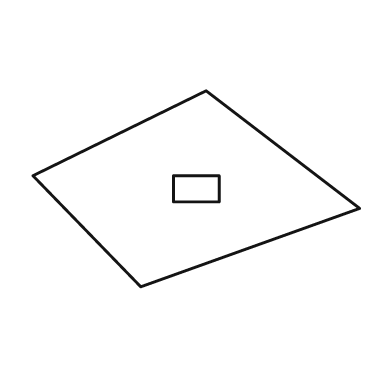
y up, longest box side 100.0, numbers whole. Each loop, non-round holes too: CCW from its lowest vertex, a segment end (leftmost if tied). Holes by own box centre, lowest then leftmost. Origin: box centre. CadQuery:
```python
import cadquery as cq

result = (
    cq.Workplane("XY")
    .moveTo(-17.0, -30.0)
    .lineTo(50.0, -6.0)
    .lineTo(3.0, 30.0)
    .lineTo(-50.0, 4.0)
    .close()
    .moveTo(-7.0, -4.0)
    .lineTo(7.0, -4.0)
    .lineTo(7.0, 4.0)
    .lineTo(-7.0, 4.0)
    .close()
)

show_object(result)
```